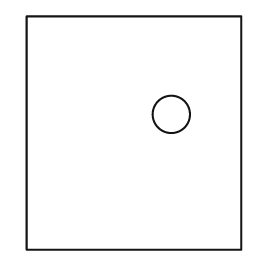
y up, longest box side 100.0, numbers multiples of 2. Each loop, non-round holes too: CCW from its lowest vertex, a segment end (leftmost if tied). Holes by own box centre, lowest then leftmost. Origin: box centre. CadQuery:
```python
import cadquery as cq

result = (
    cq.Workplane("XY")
    .moveTo(-46.0, -50.0)
    .lineTo(46.0, -50.0)
    .lineTo(46.0, 50.0)
    .lineTo(-46.0, 50.0)
    .close()
    .moveTo(16.0, 8.0)
    .circle(8.0)
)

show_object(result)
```